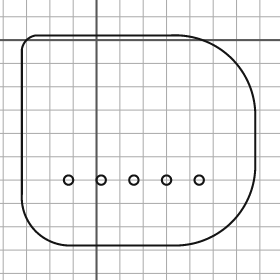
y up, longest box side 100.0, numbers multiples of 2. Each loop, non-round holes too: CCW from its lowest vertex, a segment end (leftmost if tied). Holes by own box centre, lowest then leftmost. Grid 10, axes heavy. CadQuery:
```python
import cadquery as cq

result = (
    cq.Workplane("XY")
    .moveTo(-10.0, -88.0)
    .lineTo(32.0, -88.0)
    .threePointArc((58.0, -78.0), (68.0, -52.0))
    .lineTo(68.0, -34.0)
    .threePointArc((58.0, -8.0), (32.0, 2.0))
    .lineTo(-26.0, 2.0)
    .threePointArc((-30.0, 0.0), (-32.0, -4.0))
    .lineTo(-32.0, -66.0)
    .threePointArc((-26.0, -82.0), (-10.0, -88.0))
    .close()
    .moveTo(-12.0, -60.0)
    .circle(2.0)
    .moveTo(2.0, -60.0)
    .circle(2.0)
    .moveTo(16.0, -60.0)
    .circle(2.0)
    .moveTo(30.0, -60.0)
    .circle(2.0)
    .moveTo(44.0, -60.0)
    .circle(2.0)
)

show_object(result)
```